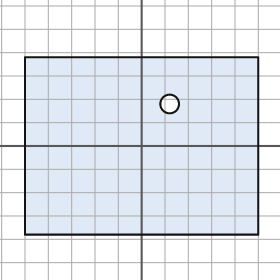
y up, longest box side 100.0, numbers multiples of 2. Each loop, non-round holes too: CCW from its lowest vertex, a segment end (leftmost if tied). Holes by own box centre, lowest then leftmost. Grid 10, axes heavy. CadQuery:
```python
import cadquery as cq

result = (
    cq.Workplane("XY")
    .moveTo(-50.0, -38.0)
    .lineTo(50.0, -38.0)
    .lineTo(50.0, 38.0)
    .lineTo(-50.0, 38.0)
    .close()
    .moveTo(12.0, 18.0)
    .circle(4.0)
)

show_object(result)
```